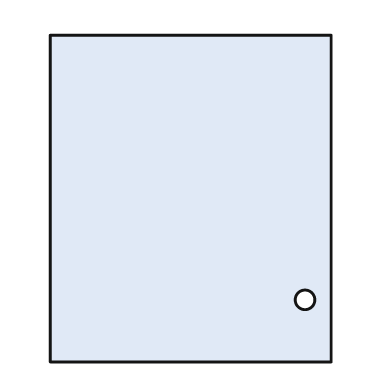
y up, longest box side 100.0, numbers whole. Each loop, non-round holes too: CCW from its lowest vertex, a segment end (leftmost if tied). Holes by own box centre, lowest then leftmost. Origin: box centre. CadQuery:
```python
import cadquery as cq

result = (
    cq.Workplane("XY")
    .moveTo(-43.0, -50.0)
    .lineTo(43.0, -50.0)
    .lineTo(43.0, 50.0)
    .lineTo(-43.0, 50.0)
    .close()
    .moveTo(35.0, -31.0)
    .circle(3.0)
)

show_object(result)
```